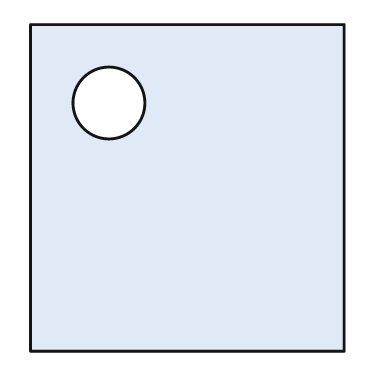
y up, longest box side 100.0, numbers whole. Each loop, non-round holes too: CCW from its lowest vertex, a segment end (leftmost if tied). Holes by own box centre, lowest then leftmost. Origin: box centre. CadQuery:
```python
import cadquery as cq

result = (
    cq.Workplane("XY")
    .moveTo(-48.0, -50.0)
    .lineTo(48.0, -50.0)
    .lineTo(48.0, 50.0)
    .lineTo(-48.0, 50.0)
    .close()
    .moveTo(-24.0, 26.0)
    .circle(11.0)
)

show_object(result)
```